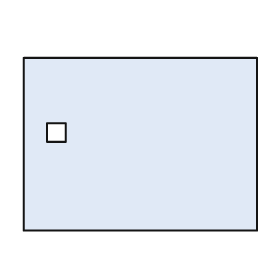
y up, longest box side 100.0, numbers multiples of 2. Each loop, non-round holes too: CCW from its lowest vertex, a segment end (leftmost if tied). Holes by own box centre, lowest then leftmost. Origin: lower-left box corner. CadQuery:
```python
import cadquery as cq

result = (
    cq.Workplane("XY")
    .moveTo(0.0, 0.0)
    .lineTo(100.0, 0.0)
    .lineTo(100.0, 74.0)
    .lineTo(0.0, 74.0)
    .close()
    .moveTo(10.0, 38.0)
    .lineTo(18.0, 38.0)
    .lineTo(18.0, 46.0)
    .lineTo(10.0, 46.0)
    .close()
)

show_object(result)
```